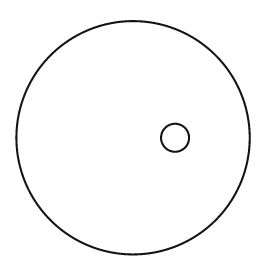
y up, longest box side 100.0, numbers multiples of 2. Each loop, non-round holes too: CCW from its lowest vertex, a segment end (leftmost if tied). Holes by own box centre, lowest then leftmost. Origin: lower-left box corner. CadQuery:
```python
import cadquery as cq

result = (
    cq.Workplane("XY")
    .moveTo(50.0, 50.0)
    .circle(50.0)
    .moveTo(68.0, 50.0)
    .circle(6.0)
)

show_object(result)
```